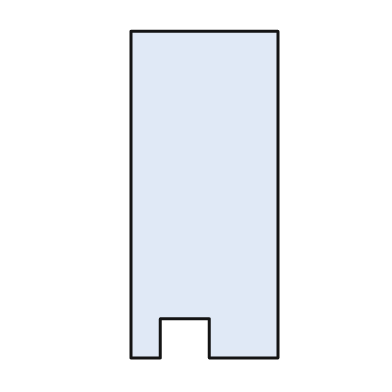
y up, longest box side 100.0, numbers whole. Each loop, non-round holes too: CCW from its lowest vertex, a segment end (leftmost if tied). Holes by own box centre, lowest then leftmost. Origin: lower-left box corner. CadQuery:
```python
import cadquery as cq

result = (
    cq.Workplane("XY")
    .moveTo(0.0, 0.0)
    .lineTo(9.0, 0.0)
    .lineTo(9.0, 12.0)
    .lineTo(24.0, 12.0)
    .lineTo(24.0, 0.0)
    .lineTo(45.0, 0.0)
    .lineTo(45.0, 100.0)
    .lineTo(0.0, 100.0)
    .close()
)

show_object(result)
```